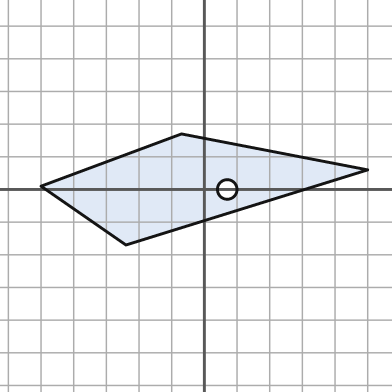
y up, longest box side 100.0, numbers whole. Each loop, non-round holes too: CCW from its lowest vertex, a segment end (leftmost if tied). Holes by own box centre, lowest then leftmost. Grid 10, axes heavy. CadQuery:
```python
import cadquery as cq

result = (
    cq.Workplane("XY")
    .moveTo(-24.0, -17.0)
    .lineTo(50.0, 6.0)
    .lineTo(-7.0, 17.0)
    .lineTo(-50.0, 1.0)
    .close()
    .moveTo(7.0, 0.0)
    .circle(3.0)
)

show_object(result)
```